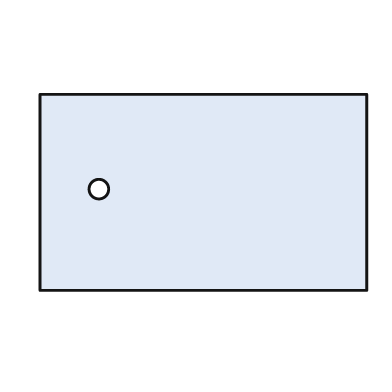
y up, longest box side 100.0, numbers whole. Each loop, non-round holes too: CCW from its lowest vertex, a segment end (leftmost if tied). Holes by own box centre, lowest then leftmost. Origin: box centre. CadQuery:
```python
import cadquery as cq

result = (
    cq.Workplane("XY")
    .moveTo(-50.0, -30.0)
    .lineTo(50.0, -30.0)
    .lineTo(50.0, 30.0)
    .lineTo(-50.0, 30.0)
    .close()
    .moveTo(-32.0, 1.0)
    .circle(3.0)
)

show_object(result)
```